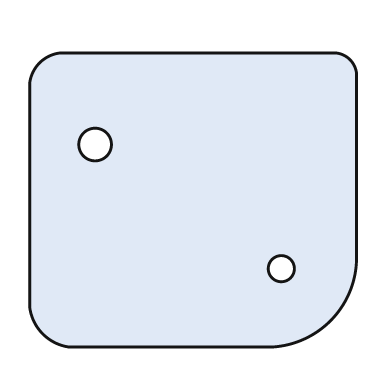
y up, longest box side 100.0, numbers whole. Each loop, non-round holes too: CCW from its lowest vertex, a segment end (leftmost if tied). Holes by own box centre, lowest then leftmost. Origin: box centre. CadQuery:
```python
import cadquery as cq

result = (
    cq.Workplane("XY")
    .moveTo(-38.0, -45.0)
    .lineTo(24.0, -45.0)
    .threePointArc((42.0, -37.0), (50.0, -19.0))
    .lineTo(50.0, 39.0)
    .threePointArc((48.0, 43.0), (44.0, 45.0))
    .lineTo(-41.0, 45.0)
    .threePointArc((-47.0, 42.0), (-50.0, 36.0))
    .lineTo(-50.0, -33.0)
    .threePointArc((-46.0, -41.0), (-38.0, -45.0))
    .close()
    .moveTo(27.0, -21.0)
    .circle(4.0)
    .moveTo(-30.0, 17.0)
    .circle(5.0)
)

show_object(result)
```